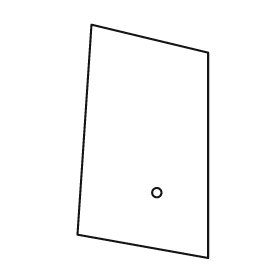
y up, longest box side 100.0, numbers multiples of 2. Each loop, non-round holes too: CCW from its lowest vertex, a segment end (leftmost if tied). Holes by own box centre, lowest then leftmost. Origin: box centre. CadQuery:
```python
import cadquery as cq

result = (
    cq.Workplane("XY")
    .moveTo(28.0, -50.0)
    .lineTo(28.0, 38.0)
    .lineTo(-22.0, 50.0)
    .lineTo(-28.0, -40.0)
    .close()
    .moveTo(6.0, -22.0)
    .circle(2.0)
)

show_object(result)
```